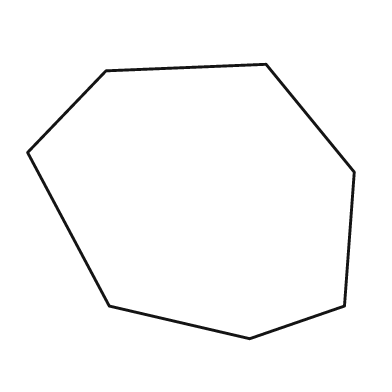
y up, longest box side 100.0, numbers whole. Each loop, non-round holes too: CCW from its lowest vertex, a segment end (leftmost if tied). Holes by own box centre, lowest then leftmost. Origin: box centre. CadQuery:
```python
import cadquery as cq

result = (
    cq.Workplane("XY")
    .moveTo(18.0, -42.0)
    .lineTo(47.0, -32.0)
    .lineTo(50.0, 9.0)
    .lineTo(23.0, 42.0)
    .lineTo(-26.0, 40.0)
    .lineTo(-50.0, 15.0)
    .lineTo(-25.0, -32.0)
    .close()
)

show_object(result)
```